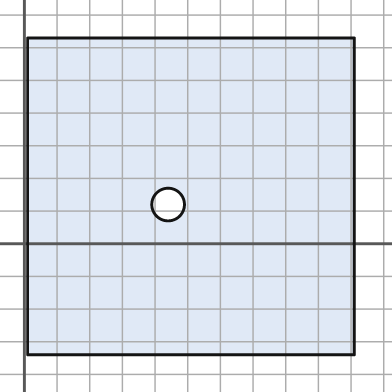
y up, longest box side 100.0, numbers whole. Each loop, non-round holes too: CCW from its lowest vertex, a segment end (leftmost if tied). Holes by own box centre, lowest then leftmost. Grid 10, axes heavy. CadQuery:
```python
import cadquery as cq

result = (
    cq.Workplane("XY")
    .moveTo(1.0, -34.0)
    .lineTo(101.0, -34.0)
    .lineTo(101.0, 63.0)
    .lineTo(1.0, 63.0)
    .close()
    .moveTo(44.0, 12.0)
    .circle(5.0)
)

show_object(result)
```